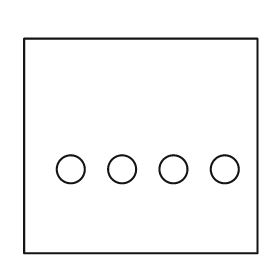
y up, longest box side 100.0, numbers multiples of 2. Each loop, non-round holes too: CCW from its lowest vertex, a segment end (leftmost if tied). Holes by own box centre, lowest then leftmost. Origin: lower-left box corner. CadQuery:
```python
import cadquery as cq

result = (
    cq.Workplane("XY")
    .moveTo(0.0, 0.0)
    .lineTo(100.0, 0.0)
    .lineTo(100.0, 92.0)
    .lineTo(0.0, 92.0)
    .close()
    .moveTo(20.0, 36.0)
    .circle(6.0)
    .moveTo(42.0, 36.0)
    .circle(6.0)
    .moveTo(64.0, 36.0)
    .circle(6.0)
    .moveTo(86.0, 36.0)
    .circle(6.0)
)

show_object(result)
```